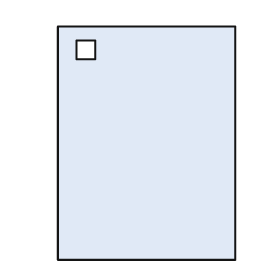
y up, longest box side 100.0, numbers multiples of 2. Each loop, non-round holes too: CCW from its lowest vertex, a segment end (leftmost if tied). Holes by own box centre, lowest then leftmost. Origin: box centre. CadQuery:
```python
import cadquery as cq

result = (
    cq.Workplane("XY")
    .moveTo(-38.0, -50.0)
    .lineTo(38.0, -50.0)
    .lineTo(38.0, 50.0)
    .lineTo(-38.0, 50.0)
    .close()
    .moveTo(-30.0, 36.0)
    .lineTo(-22.0, 36.0)
    .lineTo(-22.0, 44.0)
    .lineTo(-30.0, 44.0)
    .close()
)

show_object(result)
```